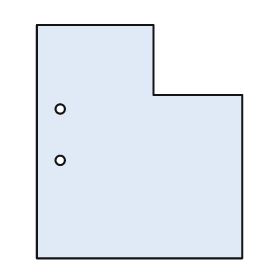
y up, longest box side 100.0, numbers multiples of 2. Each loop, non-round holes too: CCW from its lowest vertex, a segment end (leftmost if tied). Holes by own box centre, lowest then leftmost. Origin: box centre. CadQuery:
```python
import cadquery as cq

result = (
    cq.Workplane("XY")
    .moveTo(-44.0, -50.0)
    .lineTo(44.0, -50.0)
    .lineTo(44.0, 20.0)
    .lineTo(6.0, 20.0)
    .lineTo(6.0, 50.0)
    .lineTo(-44.0, 50.0)
    .close()
    .moveTo(-34.0, -8.0)
    .circle(2.0)
    .moveTo(-34.0, 14.0)
    .circle(2.0)
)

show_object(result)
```